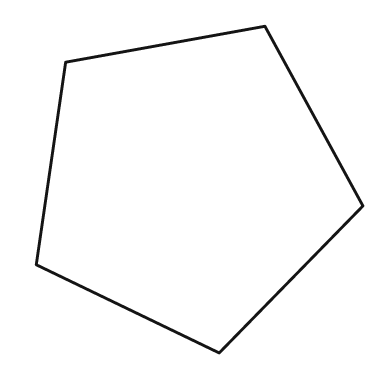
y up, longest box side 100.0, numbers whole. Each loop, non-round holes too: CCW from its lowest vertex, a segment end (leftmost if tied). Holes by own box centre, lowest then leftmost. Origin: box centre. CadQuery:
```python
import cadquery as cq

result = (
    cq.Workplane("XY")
    .moveTo(6.0, -50.0)
    .lineTo(50.0, -5.0)
    .lineTo(20.0, 50.0)
    .lineTo(-41.0, 39.0)
    .lineTo(-50.0, -23.0)
    .close()
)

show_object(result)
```